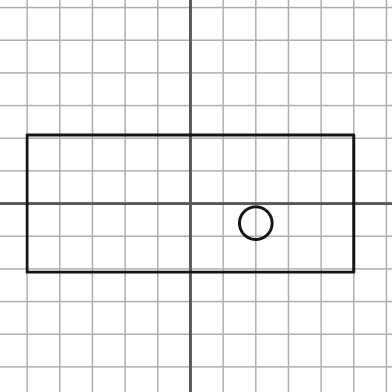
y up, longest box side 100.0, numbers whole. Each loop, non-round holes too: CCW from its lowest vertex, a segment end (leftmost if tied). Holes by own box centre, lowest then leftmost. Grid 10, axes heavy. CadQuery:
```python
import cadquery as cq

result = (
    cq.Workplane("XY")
    .moveTo(-50.0, -21.0)
    .lineTo(50.0, -21.0)
    .lineTo(50.0, 21.0)
    .lineTo(-50.0, 21.0)
    .close()
    .moveTo(20.0, -6.0)
    .circle(5.0)
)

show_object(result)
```